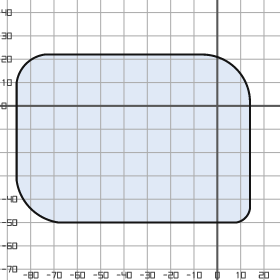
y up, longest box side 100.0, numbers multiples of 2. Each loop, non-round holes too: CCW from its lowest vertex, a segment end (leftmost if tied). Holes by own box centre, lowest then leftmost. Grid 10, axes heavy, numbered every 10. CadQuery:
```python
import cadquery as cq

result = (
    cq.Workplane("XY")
    .moveTo(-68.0, -50.0)
    .lineTo(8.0, -50.0)
    .threePointArc((12.0, -48.0), (14.0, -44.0))
    .lineTo(14.0, 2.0)
    .threePointArc((8.0, 16.0), (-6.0, 22.0))
    .lineTo(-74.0, 22.0)
    .threePointArc((-82.0, 18.0), (-86.0, 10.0))
    .lineTo(-86.0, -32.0)
    .threePointArc((-80.0, -44.0), (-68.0, -50.0))
    .close()
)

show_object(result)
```